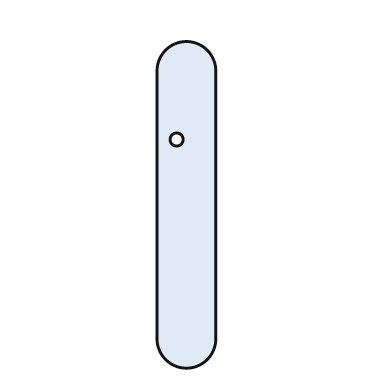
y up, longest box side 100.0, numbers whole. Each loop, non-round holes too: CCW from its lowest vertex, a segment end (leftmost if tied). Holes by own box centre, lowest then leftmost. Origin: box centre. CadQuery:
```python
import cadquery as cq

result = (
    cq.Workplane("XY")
    .moveTo(-9.0, -41.0)
    .threePointArc((0.0, -50.0), (9.0, -41.0))
    .lineTo(9.0, 41.0)
    .threePointArc((0.0, 50.0), (-9.0, 41.0))
    .close()
    .moveTo(-3.0, 20.0)
    .circle(2.0)
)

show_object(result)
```